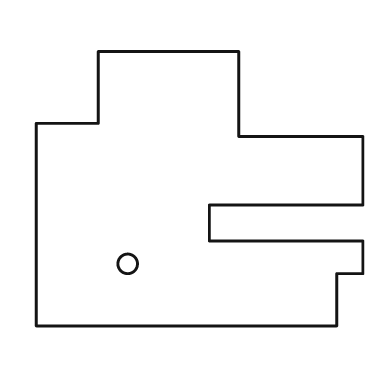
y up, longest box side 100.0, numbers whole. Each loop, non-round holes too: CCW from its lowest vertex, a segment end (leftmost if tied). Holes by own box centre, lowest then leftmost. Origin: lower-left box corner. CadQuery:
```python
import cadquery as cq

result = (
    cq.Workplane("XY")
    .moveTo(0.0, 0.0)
    .lineTo(92.0, 0.0)
    .lineTo(92.0, 16.0)
    .lineTo(100.0, 16.0)
    .lineTo(100.0, 26.0)
    .lineTo(53.0, 26.0)
    .lineTo(53.0, 37.0)
    .lineTo(100.0, 37.0)
    .lineTo(100.0, 58.0)
    .lineTo(62.0, 58.0)
    .lineTo(62.0, 84.0)
    .lineTo(19.0, 84.0)
    .lineTo(19.0, 62.0)
    .lineTo(0.0, 62.0)
    .close()
    .moveTo(28.0, 19.0)
    .circle(3.0)
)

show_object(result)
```